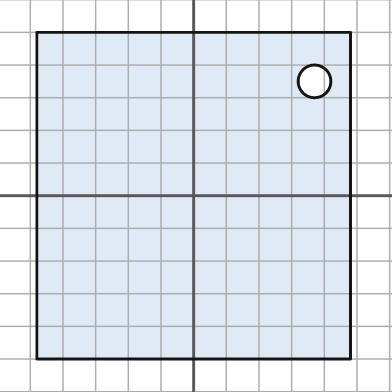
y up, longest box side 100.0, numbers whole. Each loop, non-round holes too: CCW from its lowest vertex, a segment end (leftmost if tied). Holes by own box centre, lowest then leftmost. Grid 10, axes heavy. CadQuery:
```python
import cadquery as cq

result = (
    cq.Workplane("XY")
    .moveTo(-48.0, -50.0)
    .lineTo(48.0, -50.0)
    .lineTo(48.0, 50.0)
    .lineTo(-48.0, 50.0)
    .close()
    .moveTo(37.0, 35.0)
    .circle(5.0)
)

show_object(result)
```